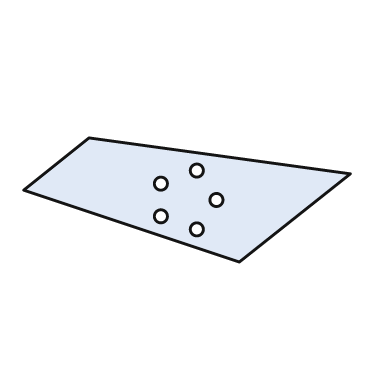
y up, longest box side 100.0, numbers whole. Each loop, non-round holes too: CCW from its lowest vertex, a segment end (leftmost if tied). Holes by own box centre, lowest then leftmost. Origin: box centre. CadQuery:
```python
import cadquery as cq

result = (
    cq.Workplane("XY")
    .moveTo(16.0, -19.0)
    .lineTo(50.0, 8.0)
    .lineTo(-30.0, 19.0)
    .lineTo(-50.0, 3.0)
    .close()
    .moveTo(3.0, -9.0)
    .circle(2.0)
    .moveTo(-8.0, -5.0)
    .circle(2.0)
    .moveTo(9.0, 0.0)
    .circle(2.0)
    .moveTo(-8.0, 5.0)
    .circle(2.0)
    .moveTo(3.0, 9.0)
    .circle(2.0)
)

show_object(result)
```